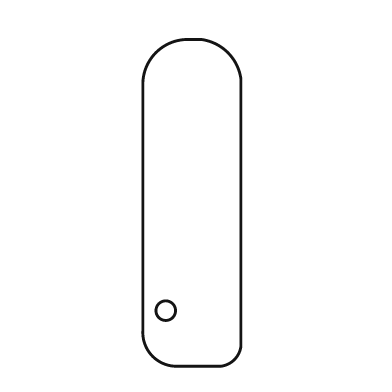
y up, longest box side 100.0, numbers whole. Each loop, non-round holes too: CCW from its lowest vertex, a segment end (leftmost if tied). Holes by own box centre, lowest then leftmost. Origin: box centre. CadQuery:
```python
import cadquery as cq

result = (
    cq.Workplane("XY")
    .moveTo(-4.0, -50.0)
    .lineTo(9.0, -50.0)
    .threePointArc((13.0, -48.0), (15.0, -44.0))
    .lineTo(15.0, 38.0)
    .threePointArc((11.0, 46.0), (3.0, 50.0))
    .lineTo(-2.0, 50.0)
    .threePointArc((-11.0, 46.0), (-15.0, 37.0))
    .lineTo(-15.0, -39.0)
    .threePointArc((-12.0, -47.0), (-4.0, -50.0))
    .close()
    .moveTo(-8.0, -33.0)
    .circle(3.0)
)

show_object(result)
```